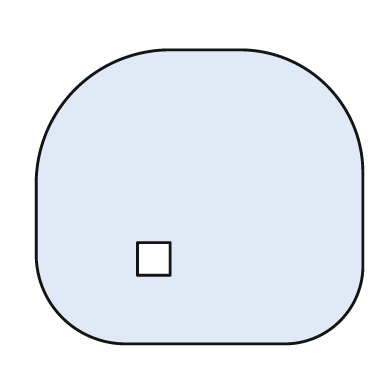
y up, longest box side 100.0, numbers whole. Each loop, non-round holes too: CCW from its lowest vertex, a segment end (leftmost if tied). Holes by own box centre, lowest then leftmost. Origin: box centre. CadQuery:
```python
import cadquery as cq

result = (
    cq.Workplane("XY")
    .moveTo(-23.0, -45.0)
    .lineTo(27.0, -45.0)
    .threePointArc((43.0, -38.0), (50.0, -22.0))
    .lineTo(50.0, 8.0)
    .threePointArc((39.0, 34.0), (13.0, 45.0))
    .lineTo(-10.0, 45.0)
    .threePointArc((-38.0, 33.0), (-50.0, 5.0))
    .lineTo(-50.0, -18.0)
    .threePointArc((-42.0, -37.0), (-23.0, -45.0))
    .close()
    .moveTo(-19.0, -24.0)
    .lineTo(-9.0, -24.0)
    .lineTo(-9.0, -14.0)
    .lineTo(-19.0, -14.0)
    .close()
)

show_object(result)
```